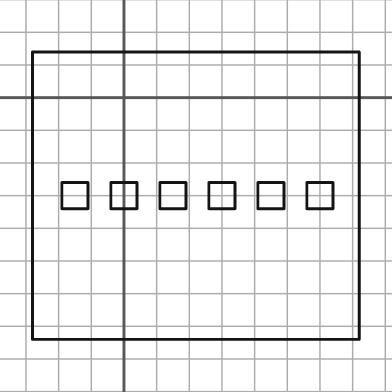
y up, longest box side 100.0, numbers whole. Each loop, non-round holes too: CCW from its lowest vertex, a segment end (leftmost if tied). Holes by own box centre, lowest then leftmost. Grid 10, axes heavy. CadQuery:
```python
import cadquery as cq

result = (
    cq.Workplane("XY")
    .moveTo(-28.0, -74.0)
    .lineTo(72.0, -74.0)
    .lineTo(72.0, 14.0)
    .lineTo(-28.0, 14.0)
    .close()
    .moveTo(-19.0, -34.0)
    .lineTo(-11.0, -34.0)
    .lineTo(-11.0, -26.0)
    .lineTo(-19.0, -26.0)
    .close()
    .moveTo(-4.0, -34.0)
    .lineTo(4.0, -34.0)
    .lineTo(4.0, -26.0)
    .lineTo(-4.0, -26.0)
    .close()
    .moveTo(11.0, -34.0)
    .lineTo(19.0, -34.0)
    .lineTo(19.0, -26.0)
    .lineTo(11.0, -26.0)
    .close()
    .moveTo(26.0, -34.0)
    .lineTo(34.0, -34.0)
    .lineTo(34.0, -26.0)
    .lineTo(26.0, -26.0)
    .close()
    .moveTo(41.0, -34.0)
    .lineTo(49.0, -34.0)
    .lineTo(49.0, -26.0)
    .lineTo(41.0, -26.0)
    .close()
    .moveTo(56.0, -34.0)
    .lineTo(64.0, -34.0)
    .lineTo(64.0, -26.0)
    .lineTo(56.0, -26.0)
    .close()
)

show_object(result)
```